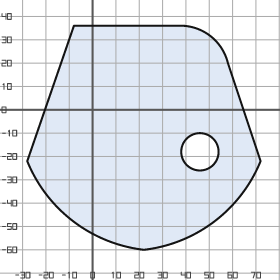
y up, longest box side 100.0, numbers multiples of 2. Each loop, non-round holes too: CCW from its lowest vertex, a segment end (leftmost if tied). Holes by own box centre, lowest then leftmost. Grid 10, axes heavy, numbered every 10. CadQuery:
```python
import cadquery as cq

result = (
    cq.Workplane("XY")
    .moveTo(22.0, -60.0)
    .threePointArc((52.0, -48.0), (72.0, -22.0))
    .lineTo(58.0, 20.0)
    .threePointArc((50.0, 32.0), (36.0, 36.0))
    .lineTo(-8.0, 36.0)
    .lineTo(-28.0, -22.0)
    .threePointArc((-8.0, -48.0), (22.0, -60.0))
    .close()
    .moveTo(46.0, -18.0)
    .circle(8.0)
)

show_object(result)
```